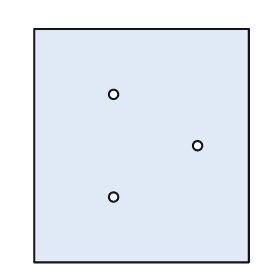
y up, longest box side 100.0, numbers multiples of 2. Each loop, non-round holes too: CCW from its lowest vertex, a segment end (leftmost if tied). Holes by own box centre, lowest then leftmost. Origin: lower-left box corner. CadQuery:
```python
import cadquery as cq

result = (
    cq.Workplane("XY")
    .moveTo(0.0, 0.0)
    .lineTo(92.0, 0.0)
    .lineTo(92.0, 100.0)
    .lineTo(0.0, 100.0)
    .close()
    .moveTo(34.0, 28.0)
    .circle(2.0)
    .moveTo(70.0, 50.0)
    .circle(2.0)
    .moveTo(34.0, 72.0)
    .circle(2.0)
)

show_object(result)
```